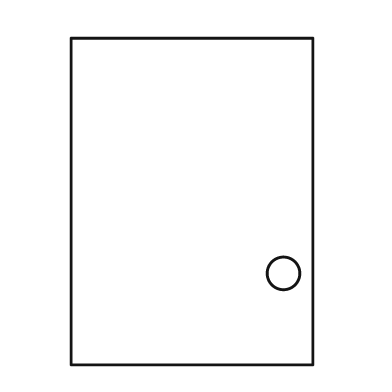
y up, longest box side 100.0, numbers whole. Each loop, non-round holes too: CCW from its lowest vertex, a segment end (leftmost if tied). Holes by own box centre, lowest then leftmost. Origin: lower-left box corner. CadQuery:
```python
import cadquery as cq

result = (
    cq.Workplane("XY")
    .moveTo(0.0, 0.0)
    .lineTo(74.0, 0.0)
    .lineTo(74.0, 100.0)
    .lineTo(0.0, 100.0)
    .close()
    .moveTo(65.0, 28.0)
    .circle(5.0)
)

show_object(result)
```